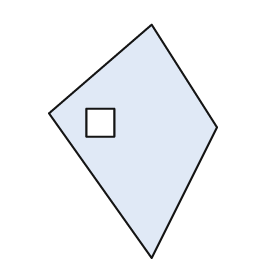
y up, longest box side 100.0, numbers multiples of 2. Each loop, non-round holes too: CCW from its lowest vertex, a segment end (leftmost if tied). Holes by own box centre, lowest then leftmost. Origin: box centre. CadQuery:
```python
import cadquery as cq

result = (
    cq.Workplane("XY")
    .moveTo(8.0, -50.0)
    .lineTo(36.0, 6.0)
    .lineTo(8.0, 50.0)
    .lineTo(-36.0, 12.0)
    .close()
    .moveTo(-20.0, 2.0)
    .lineTo(-8.0, 2.0)
    .lineTo(-8.0, 14.0)
    .lineTo(-20.0, 14.0)
    .close()
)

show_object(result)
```